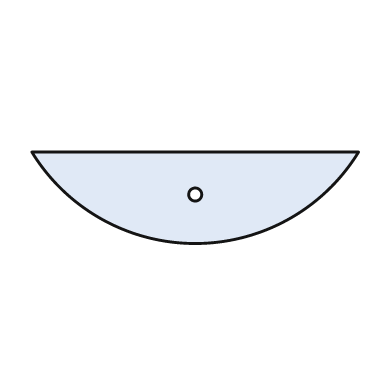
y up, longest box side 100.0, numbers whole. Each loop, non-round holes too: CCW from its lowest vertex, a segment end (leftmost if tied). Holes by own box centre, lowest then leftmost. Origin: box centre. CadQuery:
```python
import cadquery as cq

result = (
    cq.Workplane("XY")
    .moveTo(-50.0, 14.0)
    .threePointArc((0.0, -14.0), (50.0, 14.0))
    .close()
    .moveTo(0.0, 1.0)
    .circle(2.0)
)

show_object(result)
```